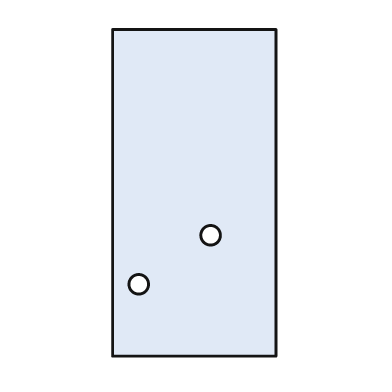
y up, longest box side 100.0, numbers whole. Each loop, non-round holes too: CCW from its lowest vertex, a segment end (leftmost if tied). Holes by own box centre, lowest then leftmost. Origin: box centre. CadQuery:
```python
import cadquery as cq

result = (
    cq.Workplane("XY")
    .moveTo(-25.0, -50.0)
    .lineTo(25.0, -50.0)
    .lineTo(25.0, 50.0)
    .lineTo(-25.0, 50.0)
    .close()
    .moveTo(-17.0, -28.0)
    .circle(3.0)
    .moveTo(5.0, -13.0)
    .circle(3.0)
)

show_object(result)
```